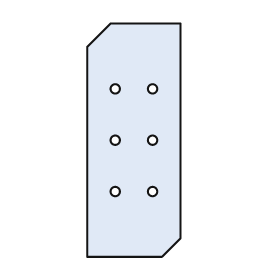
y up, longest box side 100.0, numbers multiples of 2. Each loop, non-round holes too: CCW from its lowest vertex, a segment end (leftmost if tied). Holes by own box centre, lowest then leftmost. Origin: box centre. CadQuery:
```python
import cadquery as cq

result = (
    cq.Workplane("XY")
    .moveTo(-20.0, -50.0)
    .lineTo(12.0, -50.0)
    .lineTo(20.0, -42.0)
    .lineTo(20.0, 50.0)
    .lineTo(-10.0, 50.0)
    .lineTo(-20.0, 40.0)
    .close()
    .moveTo(-8.0, -22.0)
    .circle(2.0)
    .moveTo(8.0, -22.0)
    .circle(2.0)
    .moveTo(-8.0, 0.0)
    .circle(2.0)
    .moveTo(8.0, 0.0)
    .circle(2.0)
    .moveTo(-8.0, 22.0)
    .circle(2.0)
    .moveTo(8.0, 22.0)
    .circle(2.0)
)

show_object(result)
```